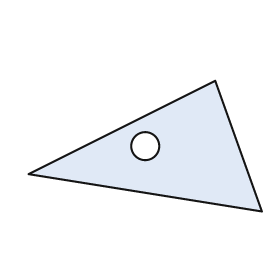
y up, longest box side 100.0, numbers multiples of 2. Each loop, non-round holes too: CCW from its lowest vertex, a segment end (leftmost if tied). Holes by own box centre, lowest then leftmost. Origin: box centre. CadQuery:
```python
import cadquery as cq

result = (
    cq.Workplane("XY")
    .moveTo(50.0, -28.0)
    .lineTo(30.0, 28.0)
    .lineTo(-50.0, -12.0)
    .close()
    .moveTo(0.0, 0.0)
    .circle(6.0)
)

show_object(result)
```